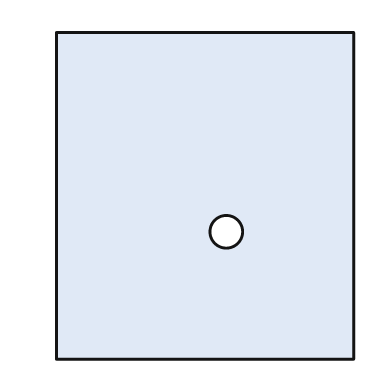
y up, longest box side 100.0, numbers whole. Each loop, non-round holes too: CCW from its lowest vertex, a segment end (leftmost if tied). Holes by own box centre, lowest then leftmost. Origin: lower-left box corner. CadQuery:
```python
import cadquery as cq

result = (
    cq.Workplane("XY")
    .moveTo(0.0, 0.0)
    .lineTo(91.0, 0.0)
    .lineTo(91.0, 100.0)
    .lineTo(0.0, 100.0)
    .close()
    .moveTo(52.0, 39.0)
    .circle(5.0)
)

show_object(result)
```